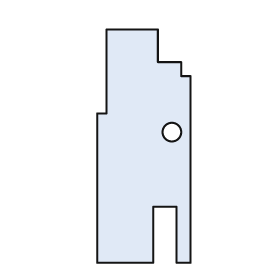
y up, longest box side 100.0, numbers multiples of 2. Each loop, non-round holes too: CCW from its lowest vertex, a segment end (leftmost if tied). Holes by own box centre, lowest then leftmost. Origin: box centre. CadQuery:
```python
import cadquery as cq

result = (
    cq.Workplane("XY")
    .moveTo(-20.0, -50.0)
    .lineTo(4.0, -50.0)
    .lineTo(4.0, -26.0)
    .lineTo(14.0, -26.0)
    .lineTo(14.0, -50.0)
    .lineTo(20.0, -50.0)
    .lineTo(20.0, 30.0)
    .lineTo(16.0, 30.0)
    .lineTo(16.0, 36.0)
    .lineTo(6.0, 36.0)
    .lineTo(6.0, 50.0)
    .lineTo(-16.0, 50.0)
    .lineTo(-16.0, 14.0)
    .lineTo(-20.0, 14.0)
    .close()
    .moveTo(12.0, 6.0)
    .circle(4.0)
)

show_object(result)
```